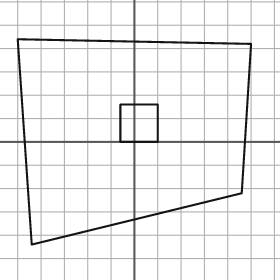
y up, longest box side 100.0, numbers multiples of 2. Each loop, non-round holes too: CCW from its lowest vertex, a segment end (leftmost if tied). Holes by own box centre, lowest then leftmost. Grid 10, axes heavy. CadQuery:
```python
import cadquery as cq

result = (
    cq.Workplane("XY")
    .moveTo(-44.0, -44.0)
    .lineTo(46.0, -22.0)
    .lineTo(50.0, 42.0)
    .lineTo(-50.0, 44.0)
    .close()
    .moveTo(-6.0, 0.0)
    .lineTo(10.0, 0.0)
    .lineTo(10.0, 16.0)
    .lineTo(-6.0, 16.0)
    .close()
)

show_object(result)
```